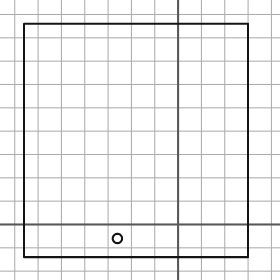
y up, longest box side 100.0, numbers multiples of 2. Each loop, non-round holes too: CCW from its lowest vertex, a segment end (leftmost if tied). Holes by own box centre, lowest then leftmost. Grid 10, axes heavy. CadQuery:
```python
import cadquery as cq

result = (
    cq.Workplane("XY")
    .moveTo(-66.0, -14.0)
    .lineTo(30.0, -14.0)
    .lineTo(30.0, 86.0)
    .lineTo(-66.0, 86.0)
    .close()
    .moveTo(-26.0, -6.0)
    .circle(2.0)
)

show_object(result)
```